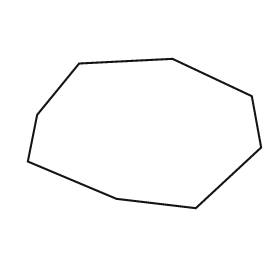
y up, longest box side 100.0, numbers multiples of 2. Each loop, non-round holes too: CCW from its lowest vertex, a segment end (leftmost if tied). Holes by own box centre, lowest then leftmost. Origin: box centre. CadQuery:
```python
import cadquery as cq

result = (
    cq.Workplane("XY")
    .moveTo(22.0, -32.0)
    .lineTo(50.0, -6.0)
    .lineTo(46.0, 16.0)
    .lineTo(12.0, 32.0)
    .lineTo(-28.0, 30.0)
    .lineTo(-46.0, 8.0)
    .lineTo(-50.0, -12.0)
    .lineTo(-12.0, -28.0)
    .close()
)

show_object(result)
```